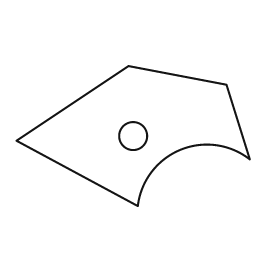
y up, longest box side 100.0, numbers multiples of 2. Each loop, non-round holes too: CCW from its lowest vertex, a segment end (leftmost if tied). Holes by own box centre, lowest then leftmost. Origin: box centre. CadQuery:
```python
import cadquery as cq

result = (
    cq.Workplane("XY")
    .moveTo(2.0, -30.0)
    .threePointArc((20.0, -6.0), (50.0, -10.0))
    .lineTo(40.0, 22.0)
    .lineTo(-2.0, 30.0)
    .lineTo(-50.0, -2.0)
    .close()
    .moveTo(0.0, 0.0)
    .circle(6.0)
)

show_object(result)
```